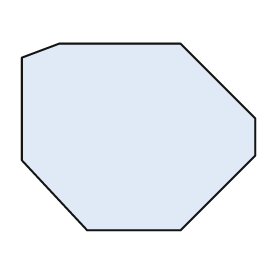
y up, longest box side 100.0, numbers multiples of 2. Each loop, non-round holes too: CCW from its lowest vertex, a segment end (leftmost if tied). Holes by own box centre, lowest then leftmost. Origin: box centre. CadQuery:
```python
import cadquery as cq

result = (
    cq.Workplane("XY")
    .moveTo(-22.0, -40.0)
    .lineTo(18.0, -40.0)
    .lineTo(50.0, -8.0)
    .lineTo(50.0, 8.0)
    .lineTo(18.0, 40.0)
    .lineTo(-34.0, 40.0)
    .lineTo(-50.0, 34.0)
    .lineTo(-50.0, -10.0)
    .close()
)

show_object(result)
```